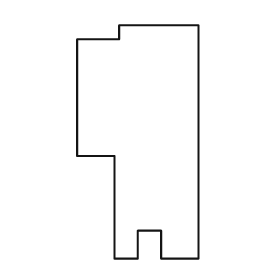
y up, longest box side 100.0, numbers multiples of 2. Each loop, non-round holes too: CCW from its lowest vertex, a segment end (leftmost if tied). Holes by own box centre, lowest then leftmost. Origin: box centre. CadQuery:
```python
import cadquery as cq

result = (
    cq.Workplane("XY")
    .moveTo(-10.0, -50.0)
    .lineTo(0.0, -50.0)
    .lineTo(0.0, -38.0)
    .lineTo(10.0, -38.0)
    .lineTo(10.0, -50.0)
    .lineTo(26.0, -50.0)
    .lineTo(26.0, 50.0)
    .lineTo(-8.0, 50.0)
    .lineTo(-8.0, 44.0)
    .lineTo(-26.0, 44.0)
    .lineTo(-26.0, -6.0)
    .lineTo(-10.0, -6.0)
    .close()
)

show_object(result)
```